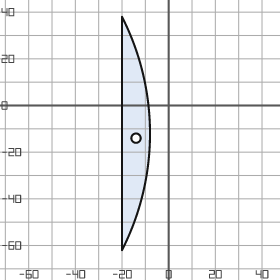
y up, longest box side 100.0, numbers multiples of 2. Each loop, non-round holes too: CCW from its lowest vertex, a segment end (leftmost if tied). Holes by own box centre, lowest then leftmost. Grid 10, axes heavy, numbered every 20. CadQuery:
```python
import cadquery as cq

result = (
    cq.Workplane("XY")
    .moveTo(-20.0, -62.0)
    .threePointArc((-8.0, -12.0), (-20.0, 38.0))
    .close()
    .moveTo(-14.0, -14.0)
    .circle(2.0)
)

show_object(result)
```